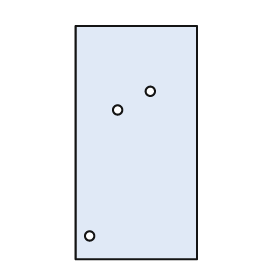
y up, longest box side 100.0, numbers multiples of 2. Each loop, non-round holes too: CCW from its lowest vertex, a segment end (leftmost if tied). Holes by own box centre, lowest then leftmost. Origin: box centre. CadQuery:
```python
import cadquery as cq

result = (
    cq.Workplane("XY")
    .moveTo(-26.0, -50.0)
    .lineTo(26.0, -50.0)
    .lineTo(26.0, 50.0)
    .lineTo(-26.0, 50.0)
    .close()
    .moveTo(-20.0, -40.0)
    .circle(2.0)
    .moveTo(-8.0, 14.0)
    .circle(2.0)
    .moveTo(6.0, 22.0)
    .circle(2.0)
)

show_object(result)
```